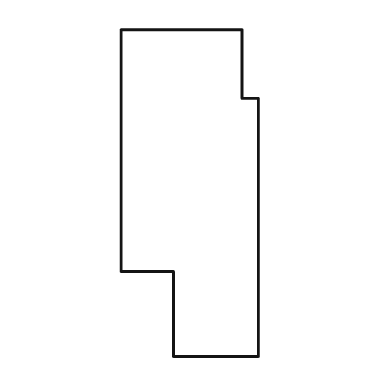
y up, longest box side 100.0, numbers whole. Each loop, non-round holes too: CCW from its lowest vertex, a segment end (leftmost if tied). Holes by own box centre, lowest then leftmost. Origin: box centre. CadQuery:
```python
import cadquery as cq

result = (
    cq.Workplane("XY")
    .moveTo(-5.0, -50.0)
    .lineTo(21.0, -50.0)
    .lineTo(21.0, 29.0)
    .lineTo(16.0, 29.0)
    .lineTo(16.0, 50.0)
    .lineTo(-21.0, 50.0)
    .lineTo(-21.0, -24.0)
    .lineTo(-5.0, -24.0)
    .close()
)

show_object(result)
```